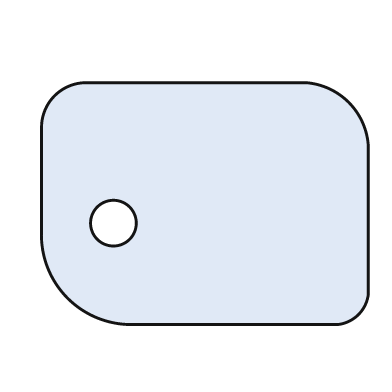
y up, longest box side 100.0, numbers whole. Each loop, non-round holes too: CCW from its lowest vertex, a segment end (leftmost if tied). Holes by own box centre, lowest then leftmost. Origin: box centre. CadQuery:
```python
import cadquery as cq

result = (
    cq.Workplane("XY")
    .moveTo(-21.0, -37.0)
    .lineTo(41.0, -37.0)
    .threePointArc((47.0, -34.0), (50.0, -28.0))
    .lineTo(50.0, 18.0)
    .threePointArc((44.0, 31.0), (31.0, 37.0))
    .lineTo(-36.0, 37.0)
    .threePointArc((-46.0, 33.0), (-50.0, 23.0))
    .lineTo(-50.0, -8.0)
    .threePointArc((-42.0, -29.0), (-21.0, -37.0))
    .close()
    .moveTo(-28.0, -6.0)
    .circle(7.0)
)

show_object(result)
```